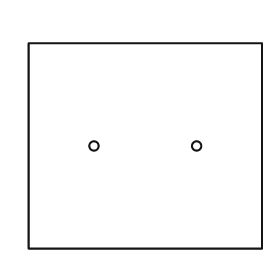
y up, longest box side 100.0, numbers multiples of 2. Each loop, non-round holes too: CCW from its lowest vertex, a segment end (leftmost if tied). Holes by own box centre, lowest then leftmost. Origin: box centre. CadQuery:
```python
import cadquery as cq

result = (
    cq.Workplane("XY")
    .moveTo(-50.0, -44.0)
    .lineTo(50.0, -44.0)
    .lineTo(50.0, 44.0)
    .lineTo(-50.0, 44.0)
    .close()
    .moveTo(-22.0, 0.0)
    .circle(2.0)
    .moveTo(22.0, 0.0)
    .circle(2.0)
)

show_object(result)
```